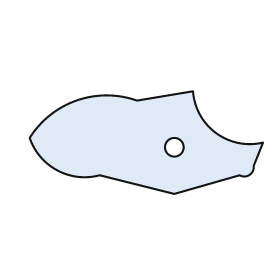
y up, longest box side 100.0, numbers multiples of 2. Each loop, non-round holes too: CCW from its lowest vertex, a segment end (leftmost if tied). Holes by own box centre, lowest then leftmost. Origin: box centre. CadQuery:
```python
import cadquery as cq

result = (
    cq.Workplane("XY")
    .moveTo(12.0, -22.0)
    .lineTo(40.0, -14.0)
    .threePointArc((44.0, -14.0), (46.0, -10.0))
    .lineTo(50.0, 0.0)
    .threePointArc((30.0, 4.0), (20.0, 22.0))
    .lineTo(-4.0, 18.0)
    .threePointArc((-30.0, 18.0), (-50.0, 2.0))
    .threePointArc((-38.0, -12.0), (-20.0, -14.0))
    .close()
    .moveTo(12.0, -2.0)
    .circle(4.0)
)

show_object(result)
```